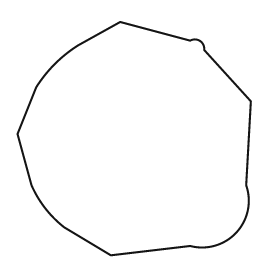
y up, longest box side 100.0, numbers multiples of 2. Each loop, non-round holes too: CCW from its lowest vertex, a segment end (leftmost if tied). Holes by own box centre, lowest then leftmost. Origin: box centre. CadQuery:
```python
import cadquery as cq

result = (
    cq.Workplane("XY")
    .moveTo(-10.0, -50.0)
    .lineTo(24.0, -46.0)
    .threePointArc((44.0, -40.0), (48.0, -20.0))
    .lineTo(50.0, 16.0)
    .lineTo(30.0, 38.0)
    .threePointArc((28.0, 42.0), (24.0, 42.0))
    .lineTo(-6.0, 50.0)
    .lineTo(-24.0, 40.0)
    .threePointArc((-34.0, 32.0), (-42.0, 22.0))
    .lineTo(-50.0, 2.0)
    .lineTo(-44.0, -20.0)
    .threePointArc((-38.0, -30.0), (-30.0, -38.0))
    .close()
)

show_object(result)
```